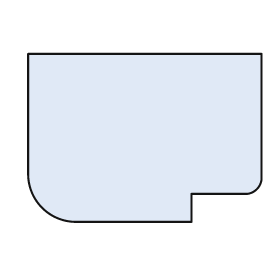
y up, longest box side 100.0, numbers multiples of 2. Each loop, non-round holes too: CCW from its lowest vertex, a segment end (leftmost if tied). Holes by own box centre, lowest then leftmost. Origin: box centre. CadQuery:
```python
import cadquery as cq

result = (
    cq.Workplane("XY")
    .moveTo(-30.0, -36.0)
    .lineTo(20.0, -36.0)
    .lineTo(20.0, -24.0)
    .lineTo(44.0, -24.0)
    .threePointArc((48.0, -22.0), (50.0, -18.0))
    .lineTo(50.0, 36.0)
    .lineTo(-50.0, 36.0)
    .lineTo(-50.0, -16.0)
    .threePointArc((-44.0, -30.0), (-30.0, -36.0))
    .close()
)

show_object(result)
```